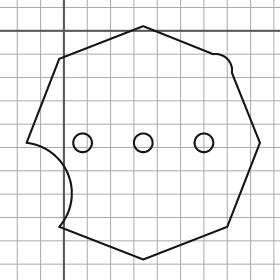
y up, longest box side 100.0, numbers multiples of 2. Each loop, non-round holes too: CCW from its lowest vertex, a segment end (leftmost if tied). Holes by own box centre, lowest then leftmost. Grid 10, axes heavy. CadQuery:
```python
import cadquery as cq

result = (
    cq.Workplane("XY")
    .moveTo(34.0, -98.0)
    .lineTo(70.0, -84.0)
    .lineTo(84.0, -48.0)
    .lineTo(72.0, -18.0)
    .threePointArc((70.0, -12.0), (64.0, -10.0))
    .lineTo(34.0, 2.0)
    .lineTo(-2.0, -12.0)
    .lineTo(-16.0, -48.0)
    .threePointArc((2.0, -62.0), (-2.0, -84.0))
    .close()
    .moveTo(8.0, -48.0)
    .circle(4.0)
    .moveTo(34.0, -48.0)
    .circle(4.0)
    .moveTo(60.0, -48.0)
    .circle(4.0)
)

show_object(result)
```